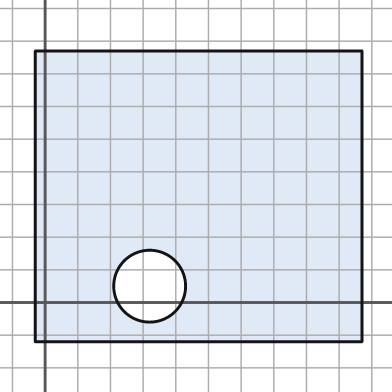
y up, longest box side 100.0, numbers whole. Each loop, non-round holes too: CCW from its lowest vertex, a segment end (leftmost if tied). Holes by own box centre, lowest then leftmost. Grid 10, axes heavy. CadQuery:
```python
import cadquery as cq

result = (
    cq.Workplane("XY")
    .moveTo(-3.0, -12.0)
    .lineTo(97.0, -12.0)
    .lineTo(97.0, 77.0)
    .lineTo(-3.0, 77.0)
    .close()
    .moveTo(32.0, 5.0)
    .circle(11.0)
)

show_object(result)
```